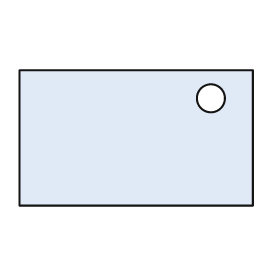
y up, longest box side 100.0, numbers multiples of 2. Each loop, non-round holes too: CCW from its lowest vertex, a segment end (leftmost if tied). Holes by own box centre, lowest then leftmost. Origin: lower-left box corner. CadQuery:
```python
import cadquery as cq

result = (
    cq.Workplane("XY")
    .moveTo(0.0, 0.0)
    .lineTo(100.0, 0.0)
    .lineTo(100.0, 58.0)
    .lineTo(0.0, 58.0)
    .close()
    .moveTo(82.0, 46.0)
    .circle(6.0)
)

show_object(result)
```